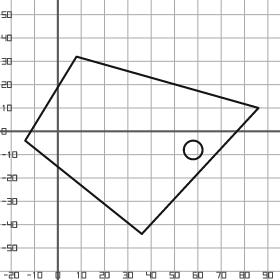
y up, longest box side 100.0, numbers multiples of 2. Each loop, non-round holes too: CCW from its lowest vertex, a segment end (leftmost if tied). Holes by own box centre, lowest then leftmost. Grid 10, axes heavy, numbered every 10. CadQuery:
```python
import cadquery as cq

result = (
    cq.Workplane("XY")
    .moveTo(36.0, -44.0)
    .lineTo(86.0, 10.0)
    .lineTo(8.0, 32.0)
    .lineTo(-14.0, -4.0)
    .close()
    .moveTo(58.0, -8.0)
    .circle(4.0)
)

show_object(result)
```